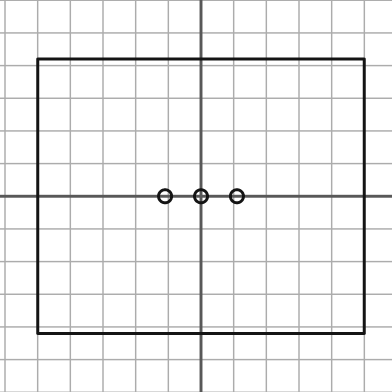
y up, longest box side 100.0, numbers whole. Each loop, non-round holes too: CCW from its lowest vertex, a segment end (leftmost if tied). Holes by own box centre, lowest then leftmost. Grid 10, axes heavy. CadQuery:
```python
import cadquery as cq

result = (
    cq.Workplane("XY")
    .moveTo(-50.0, -42.0)
    .lineTo(50.0, -42.0)
    .lineTo(50.0, 42.0)
    .lineTo(-50.0, 42.0)
    .close()
    .moveTo(-11.0, 0.0)
    .circle(2.0)
    .moveTo(0.0, 0.0)
    .circle(2.0)
    .moveTo(11.0, 0.0)
    .circle(2.0)
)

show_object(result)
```